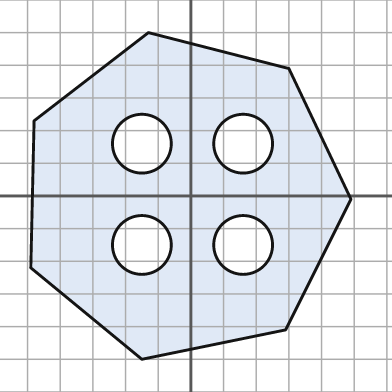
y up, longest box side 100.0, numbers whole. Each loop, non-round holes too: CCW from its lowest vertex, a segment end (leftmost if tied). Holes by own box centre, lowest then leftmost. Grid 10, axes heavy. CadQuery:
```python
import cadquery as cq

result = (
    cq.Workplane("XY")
    .moveTo(-15.0, -50.0)
    .lineTo(29.0, -41.0)
    .lineTo(49.0, -1.0)
    .lineTo(30.0, 39.0)
    .lineTo(-13.0, 50.0)
    .lineTo(-48.0, 23.0)
    .lineTo(-49.0, -22.0)
    .close()
    .moveTo(-15.0, -15.0)
    .circle(9.0)
    .moveTo(16.0, -15.0)
    .circle(9.0)
    .moveTo(-15.0, 16.0)
    .circle(9.0)
    .moveTo(16.0, 16.0)
    .circle(9.0)
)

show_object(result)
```